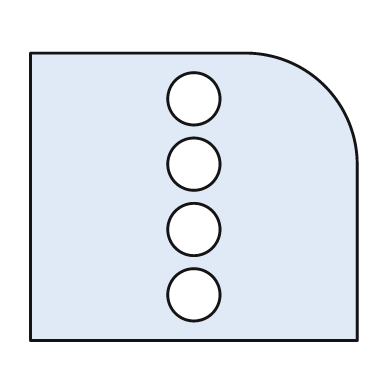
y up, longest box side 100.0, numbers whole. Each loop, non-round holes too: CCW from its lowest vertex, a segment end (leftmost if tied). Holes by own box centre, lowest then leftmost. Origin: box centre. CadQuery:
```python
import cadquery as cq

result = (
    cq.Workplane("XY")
    .moveTo(-50.0, -44.0)
    .lineTo(50.0, -44.0)
    .lineTo(50.0, 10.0)
    .threePointArc((40.0, 34.0), (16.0, 44.0))
    .lineTo(-50.0, 44.0)
    .close()
    .moveTo(0.0, -30.0)
    .circle(8.0)
    .moveTo(0.0, -10.0)
    .circle(8.0)
    .moveTo(0.0, 10.0)
    .circle(8.0)
    .moveTo(0.0, 30.0)
    .circle(8.0)
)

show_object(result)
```